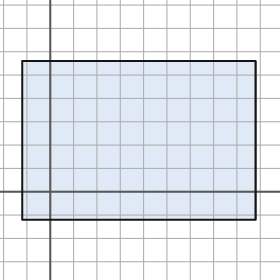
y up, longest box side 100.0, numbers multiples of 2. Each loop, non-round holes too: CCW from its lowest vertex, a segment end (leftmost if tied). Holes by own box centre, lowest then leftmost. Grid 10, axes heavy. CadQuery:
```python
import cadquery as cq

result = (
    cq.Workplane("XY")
    .moveTo(-12.0, -12.0)
    .lineTo(88.0, -12.0)
    .lineTo(88.0, 56.0)
    .lineTo(-12.0, 56.0)
    .close()
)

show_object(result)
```